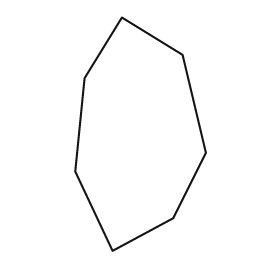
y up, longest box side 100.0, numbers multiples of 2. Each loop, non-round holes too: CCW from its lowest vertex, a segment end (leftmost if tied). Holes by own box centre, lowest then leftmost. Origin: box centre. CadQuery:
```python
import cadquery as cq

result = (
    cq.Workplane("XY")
    .moveTo(-12.0, -50.0)
    .lineTo(14.0, -36.0)
    .lineTo(28.0, -8.0)
    .lineTo(18.0, 34.0)
    .lineTo(-8.0, 50.0)
    .lineTo(-24.0, 24.0)
    .lineTo(-28.0, -16.0)
    .close()
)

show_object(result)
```